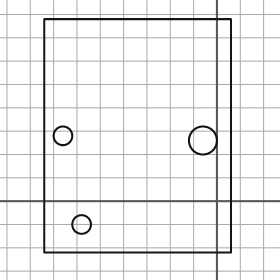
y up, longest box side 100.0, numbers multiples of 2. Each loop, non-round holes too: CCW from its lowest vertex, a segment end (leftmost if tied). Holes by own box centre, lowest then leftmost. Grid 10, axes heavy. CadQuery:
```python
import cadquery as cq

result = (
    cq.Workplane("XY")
    .moveTo(-74.0, -22.0)
    .lineTo(6.0, -22.0)
    .lineTo(6.0, 78.0)
    .lineTo(-74.0, 78.0)
    .close()
    .moveTo(-58.0, -10.0)
    .circle(4.0)
    .moveTo(-6.0, 26.0)
    .circle(6.0)
    .moveTo(-66.0, 28.0)
    .circle(4.0)
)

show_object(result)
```